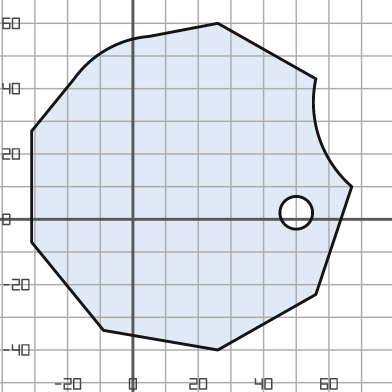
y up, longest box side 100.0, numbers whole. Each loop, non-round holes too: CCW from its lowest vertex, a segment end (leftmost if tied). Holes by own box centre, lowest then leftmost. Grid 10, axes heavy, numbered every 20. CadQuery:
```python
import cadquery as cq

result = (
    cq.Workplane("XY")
    .moveTo(26.0, -40.0)
    .lineTo(56.0, -23.0)
    .lineTo(67.0, 10.0)
    .threePointArc((57.0, 25.0), (56.0, 43.0))
    .lineTo(26.0, 60.0)
    .lineTo(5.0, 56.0)
    .threePointArc((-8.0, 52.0), (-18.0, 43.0))
    .lineTo(-31.0, 27.0)
    .lineTo(-31.0, -7.0)
    .lineTo(-9.0, -34.0)
    .close()
    .moveTo(50.0, 2.0)
    .circle(5.0)
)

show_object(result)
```